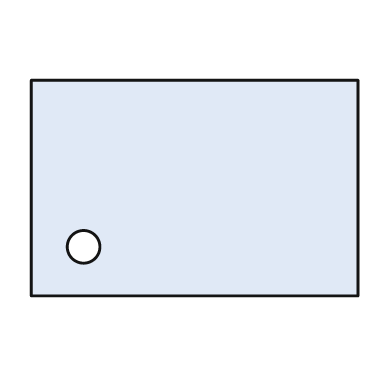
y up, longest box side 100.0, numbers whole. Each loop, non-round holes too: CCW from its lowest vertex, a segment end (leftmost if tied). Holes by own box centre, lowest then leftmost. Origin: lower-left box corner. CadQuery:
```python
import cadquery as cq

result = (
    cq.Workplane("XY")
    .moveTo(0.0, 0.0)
    .lineTo(100.0, 0.0)
    .lineTo(100.0, 66.0)
    .lineTo(0.0, 66.0)
    .close()
    .moveTo(16.0, 15.0)
    .circle(5.0)
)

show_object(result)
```